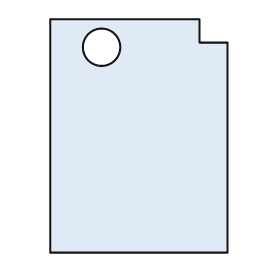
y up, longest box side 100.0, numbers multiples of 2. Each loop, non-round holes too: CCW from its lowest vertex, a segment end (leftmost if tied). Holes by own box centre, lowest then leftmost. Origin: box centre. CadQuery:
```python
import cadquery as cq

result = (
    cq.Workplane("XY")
    .moveTo(-38.0, -50.0)
    .lineTo(38.0, -50.0)
    .lineTo(38.0, 40.0)
    .lineTo(26.0, 40.0)
    .lineTo(26.0, 50.0)
    .lineTo(-38.0, 50.0)
    .close()
    .moveTo(-16.0, 38.0)
    .circle(8.0)
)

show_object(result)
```